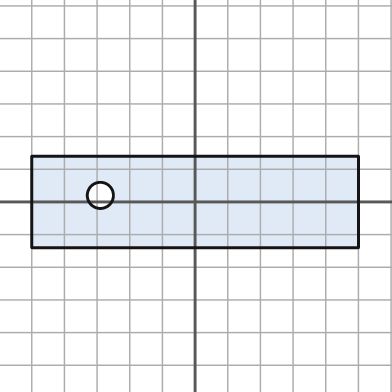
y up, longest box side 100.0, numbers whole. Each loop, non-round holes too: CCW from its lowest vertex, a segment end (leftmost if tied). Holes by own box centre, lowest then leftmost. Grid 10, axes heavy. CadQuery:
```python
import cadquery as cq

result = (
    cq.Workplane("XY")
    .moveTo(-50.0, -14.0)
    .lineTo(50.0, -14.0)
    .lineTo(50.0, 14.0)
    .lineTo(-50.0, 14.0)
    .close()
    .moveTo(-29.0, 2.0)
    .circle(4.0)
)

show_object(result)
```